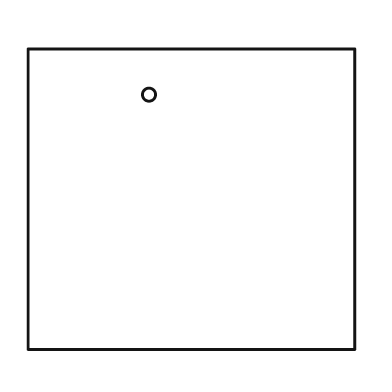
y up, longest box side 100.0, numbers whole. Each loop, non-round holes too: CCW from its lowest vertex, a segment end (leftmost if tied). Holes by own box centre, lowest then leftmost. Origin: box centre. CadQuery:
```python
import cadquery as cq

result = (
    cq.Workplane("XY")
    .moveTo(-50.0, -46.0)
    .lineTo(50.0, -46.0)
    .lineTo(50.0, 46.0)
    .lineTo(-50.0, 46.0)
    .close()
    .moveTo(-13.0, 32.0)
    .circle(2.0)
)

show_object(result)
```